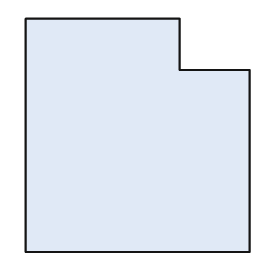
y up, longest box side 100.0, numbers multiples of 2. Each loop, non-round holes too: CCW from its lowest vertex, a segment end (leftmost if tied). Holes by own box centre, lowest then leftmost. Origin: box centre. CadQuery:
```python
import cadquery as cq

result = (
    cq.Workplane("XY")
    .moveTo(-48.0, -50.0)
    .lineTo(48.0, -50.0)
    .lineTo(48.0, 28.0)
    .lineTo(18.0, 28.0)
    .lineTo(18.0, 50.0)
    .lineTo(-48.0, 50.0)
    .close()
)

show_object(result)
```